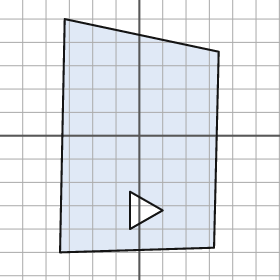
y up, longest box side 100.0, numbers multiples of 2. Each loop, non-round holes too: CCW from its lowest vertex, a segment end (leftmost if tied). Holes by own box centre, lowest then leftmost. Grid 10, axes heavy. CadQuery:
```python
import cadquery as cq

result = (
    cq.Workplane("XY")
    .moveTo(-34.0, -50.0)
    .lineTo(32.0, -48.0)
    .lineTo(34.0, 36.0)
    .lineTo(-32.0, 50.0)
    .close()
    .moveTo(-4.0, -40.0)
    .lineTo(10.0, -32.0)
    .lineTo(-4.0, -24.0)
    .close()
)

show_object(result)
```